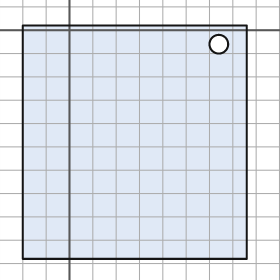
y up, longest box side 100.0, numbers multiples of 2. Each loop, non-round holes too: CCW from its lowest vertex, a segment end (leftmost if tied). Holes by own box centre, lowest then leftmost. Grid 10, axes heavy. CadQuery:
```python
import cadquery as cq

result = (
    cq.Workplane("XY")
    .moveTo(-20.0, -98.0)
    .lineTo(76.0, -98.0)
    .lineTo(76.0, 2.0)
    .lineTo(-20.0, 2.0)
    .close()
    .moveTo(64.0, -6.0)
    .circle(4.0)
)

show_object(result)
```